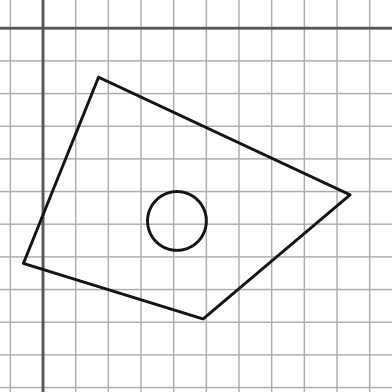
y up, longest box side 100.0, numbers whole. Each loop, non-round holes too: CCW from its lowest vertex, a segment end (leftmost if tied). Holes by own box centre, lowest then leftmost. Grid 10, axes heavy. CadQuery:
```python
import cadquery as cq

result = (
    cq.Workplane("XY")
    .moveTo(49.0, -89.0)
    .lineTo(94.0, -51.0)
    .lineTo(17.0, -15.0)
    .lineTo(-6.0, -72.0)
    .close()
    .moveTo(41.0, -59.0)
    .circle(9.0)
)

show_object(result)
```